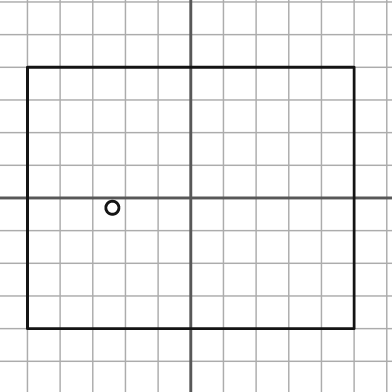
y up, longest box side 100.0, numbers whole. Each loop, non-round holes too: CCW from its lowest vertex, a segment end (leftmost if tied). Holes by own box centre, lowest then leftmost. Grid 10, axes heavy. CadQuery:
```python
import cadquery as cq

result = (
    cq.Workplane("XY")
    .moveTo(-50.0, -40.0)
    .lineTo(50.0, -40.0)
    .lineTo(50.0, 40.0)
    .lineTo(-50.0, 40.0)
    .close()
    .moveTo(-24.0, -3.0)
    .circle(2.0)
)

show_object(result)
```